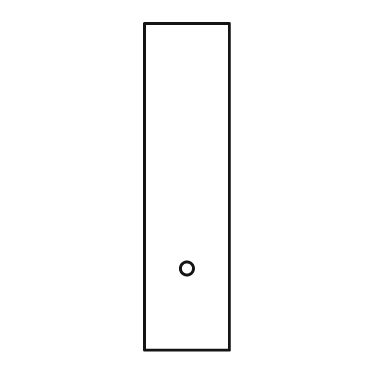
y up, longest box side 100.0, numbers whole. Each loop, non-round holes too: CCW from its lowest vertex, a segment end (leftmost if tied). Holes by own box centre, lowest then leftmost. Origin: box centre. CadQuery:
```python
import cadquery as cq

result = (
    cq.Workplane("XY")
    .moveTo(-13.0, -50.0)
    .lineTo(13.0, -50.0)
    .lineTo(13.0, 50.0)
    .lineTo(-13.0, 50.0)
    .close()
    .moveTo(0.0, -25.0)
    .circle(2.0)
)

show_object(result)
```